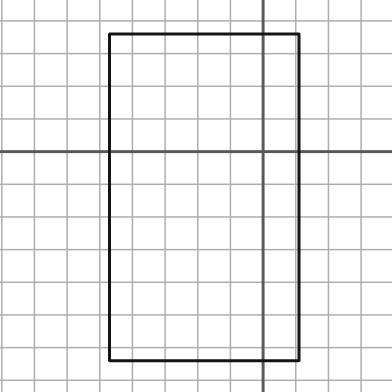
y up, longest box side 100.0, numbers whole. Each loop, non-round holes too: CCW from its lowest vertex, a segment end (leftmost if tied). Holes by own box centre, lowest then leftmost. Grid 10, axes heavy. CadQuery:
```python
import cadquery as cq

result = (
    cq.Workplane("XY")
    .moveTo(-47.0, -64.0)
    .lineTo(11.0, -64.0)
    .lineTo(11.0, 36.0)
    .lineTo(-47.0, 36.0)
    .close()
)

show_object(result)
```